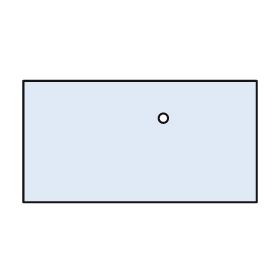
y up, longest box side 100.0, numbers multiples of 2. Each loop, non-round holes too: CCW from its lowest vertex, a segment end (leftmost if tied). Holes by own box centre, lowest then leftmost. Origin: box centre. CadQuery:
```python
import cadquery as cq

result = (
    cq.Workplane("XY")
    .moveTo(-50.0, -26.0)
    .lineTo(50.0, -26.0)
    .lineTo(50.0, 26.0)
    .lineTo(-50.0, 26.0)
    .close()
    .moveTo(10.0, 10.0)
    .circle(2.0)
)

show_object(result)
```